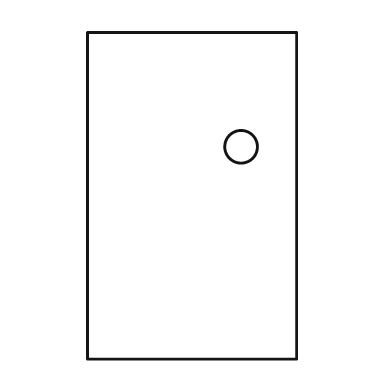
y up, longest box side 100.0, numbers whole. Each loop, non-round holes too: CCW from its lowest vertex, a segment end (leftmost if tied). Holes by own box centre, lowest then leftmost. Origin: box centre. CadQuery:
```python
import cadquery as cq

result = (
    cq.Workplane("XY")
    .moveTo(-32.0, -50.0)
    .lineTo(32.0, -50.0)
    .lineTo(32.0, 50.0)
    .lineTo(-32.0, 50.0)
    .close()
    .moveTo(15.0, 15.0)
    .circle(5.0)
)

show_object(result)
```